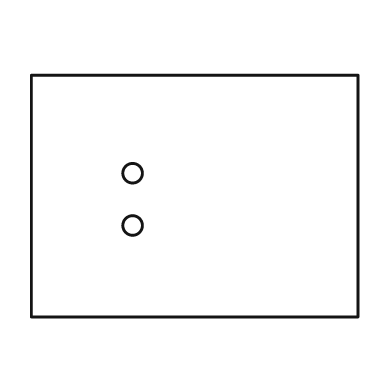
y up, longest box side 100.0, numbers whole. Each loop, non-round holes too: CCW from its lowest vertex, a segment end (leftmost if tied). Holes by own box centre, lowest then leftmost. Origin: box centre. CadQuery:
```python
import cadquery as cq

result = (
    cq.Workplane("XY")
    .moveTo(-50.0, -37.0)
    .lineTo(50.0, -37.0)
    .lineTo(50.0, 37.0)
    .lineTo(-50.0, 37.0)
    .close()
    .moveTo(-19.0, -9.0)
    .circle(3.0)
    .moveTo(-19.0, 7.0)
    .circle(3.0)
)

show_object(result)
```